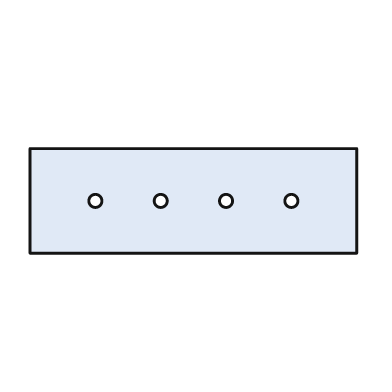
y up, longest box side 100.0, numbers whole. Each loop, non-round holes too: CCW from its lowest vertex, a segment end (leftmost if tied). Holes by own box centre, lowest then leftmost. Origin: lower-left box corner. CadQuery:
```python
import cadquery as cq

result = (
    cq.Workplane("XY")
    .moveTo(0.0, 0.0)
    .lineTo(100.0, 0.0)
    .lineTo(100.0, 32.0)
    .lineTo(0.0, 32.0)
    .close()
    .moveTo(20.0, 16.0)
    .circle(2.0)
    .moveTo(40.0, 16.0)
    .circle(2.0)
    .moveTo(60.0, 16.0)
    .circle(2.0)
    .moveTo(80.0, 16.0)
    .circle(2.0)
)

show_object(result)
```